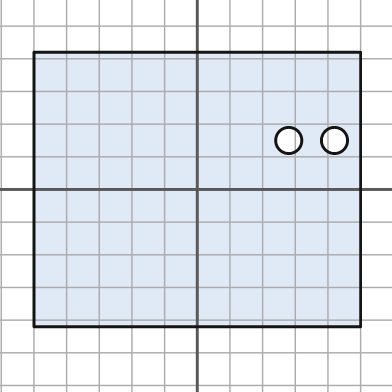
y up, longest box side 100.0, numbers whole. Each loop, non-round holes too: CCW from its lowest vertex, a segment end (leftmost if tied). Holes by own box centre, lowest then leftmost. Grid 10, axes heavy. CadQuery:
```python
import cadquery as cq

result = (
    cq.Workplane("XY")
    .moveTo(-50.0, -42.0)
    .lineTo(50.0, -42.0)
    .lineTo(50.0, 42.0)
    .lineTo(-50.0, 42.0)
    .close()
    .moveTo(28.0, 15.0)
    .circle(4.0)
    .moveTo(42.0, 15.0)
    .circle(4.0)
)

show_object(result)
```